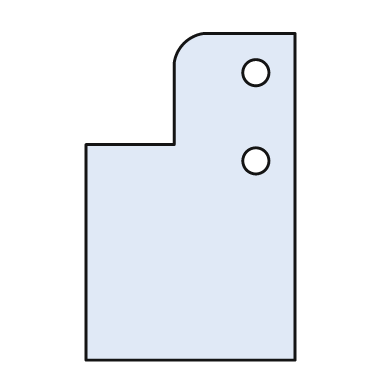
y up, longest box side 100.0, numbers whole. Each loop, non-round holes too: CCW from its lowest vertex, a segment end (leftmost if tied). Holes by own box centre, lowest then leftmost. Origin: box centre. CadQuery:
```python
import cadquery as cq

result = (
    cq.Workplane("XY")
    .moveTo(-32.0, -50.0)
    .lineTo(32.0, -50.0)
    .lineTo(32.0, 50.0)
    .lineTo(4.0, 50.0)
    .threePointArc((-2.0, 47.0), (-5.0, 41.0))
    .lineTo(-5.0, 16.0)
    .lineTo(-32.0, 16.0)
    .close()
    .moveTo(20.0, 11.0)
    .circle(4.0)
    .moveTo(20.0, 38.0)
    .circle(4.0)
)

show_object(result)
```